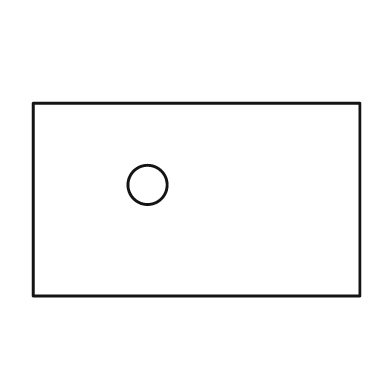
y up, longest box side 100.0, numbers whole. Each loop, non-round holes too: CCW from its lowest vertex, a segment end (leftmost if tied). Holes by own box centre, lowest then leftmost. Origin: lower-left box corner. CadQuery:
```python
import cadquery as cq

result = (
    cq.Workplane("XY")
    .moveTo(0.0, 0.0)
    .lineTo(100.0, 0.0)
    .lineTo(100.0, 59.0)
    .lineTo(0.0, 59.0)
    .close()
    .moveTo(35.0, 34.0)
    .circle(6.0)
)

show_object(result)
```